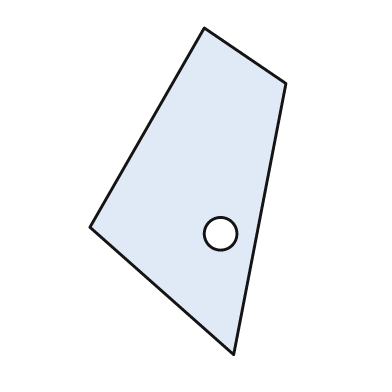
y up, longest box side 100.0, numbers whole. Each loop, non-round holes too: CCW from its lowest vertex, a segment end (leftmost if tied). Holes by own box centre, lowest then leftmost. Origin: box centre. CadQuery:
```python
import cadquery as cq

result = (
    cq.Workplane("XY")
    .moveTo(14.0, -50.0)
    .lineTo(30.0, 33.0)
    .lineTo(5.0, 50.0)
    .lineTo(-30.0, -11.0)
    .close()
    .moveTo(10.0, -13.0)
    .circle(5.0)
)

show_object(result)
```